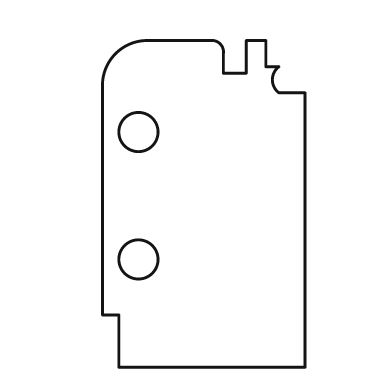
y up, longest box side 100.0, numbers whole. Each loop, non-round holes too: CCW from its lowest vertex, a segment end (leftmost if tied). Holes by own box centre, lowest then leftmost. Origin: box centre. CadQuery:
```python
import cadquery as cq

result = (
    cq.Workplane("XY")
    .moveTo(-26.0, -50.0)
    .lineTo(31.0, -50.0)
    .lineTo(31.0, 34.0)
    .lineTo(23.0, 34.0)
    .threePointArc((21.0, 38.0), (23.0, 42.0))
    .lineTo(19.0, 42.0)
    .lineTo(19.0, 50.0)
    .lineTo(13.0, 50.0)
    .lineTo(13.0, 40.0)
    .lineTo(6.0, 40.0)
    .lineTo(6.0, 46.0)
    .threePointArc((5.0, 49.0), (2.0, 50.0))
    .lineTo(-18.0, 50.0)
    .threePointArc((-27.0, 46.0), (-31.0, 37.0))
    .lineTo(-31.0, -34.0)
    .lineTo(-26.0, -34.0)
    .close()
    .moveTo(-20.0, -17.0)
    .circle(6.0)
    .moveTo(-20.0, 22.0)
    .circle(6.0)
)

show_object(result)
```